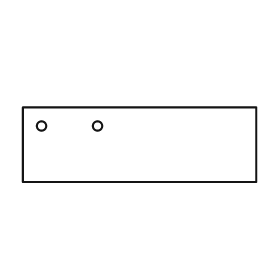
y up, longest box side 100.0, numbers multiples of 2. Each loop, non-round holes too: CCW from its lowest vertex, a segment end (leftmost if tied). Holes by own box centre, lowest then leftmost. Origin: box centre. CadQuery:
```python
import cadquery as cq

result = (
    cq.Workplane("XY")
    .moveTo(-50.0, -16.0)
    .lineTo(50.0, -16.0)
    .lineTo(50.0, 16.0)
    .lineTo(-50.0, 16.0)
    .close()
    .moveTo(-42.0, 8.0)
    .circle(2.0)
    .moveTo(-18.0, 8.0)
    .circle(2.0)
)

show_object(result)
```